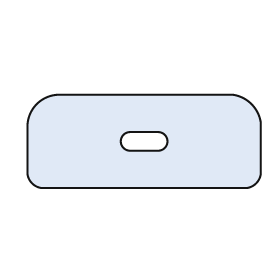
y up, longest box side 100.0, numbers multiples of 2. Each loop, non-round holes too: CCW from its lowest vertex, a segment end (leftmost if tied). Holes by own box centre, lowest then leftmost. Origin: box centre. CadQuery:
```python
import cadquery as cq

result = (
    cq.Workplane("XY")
    .moveTo(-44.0, -20.0)
    .lineTo(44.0, -20.0)
    .threePointArc((48.0, -18.0), (50.0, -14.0))
    .lineTo(50.0, 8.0)
    .threePointArc((46.0, 16.0), (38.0, 20.0))
    .lineTo(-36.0, 20.0)
    .threePointArc((-46.0, 16.0), (-50.0, 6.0))
    .lineTo(-50.0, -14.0)
    .threePointArc((-48.0, -18.0), (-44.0, -20.0))
    .close()
    .moveTo(-6.0, -4.0)
    .lineTo(6.0, -4.0)
    .threePointArc((10.0, 0.0), (6.0, 4.0))
    .lineTo(-6.0, 4.0)
    .threePointArc((-10.0, 0.0), (-6.0, -4.0))
    .close()
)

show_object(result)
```